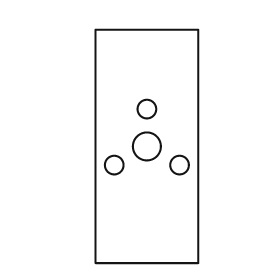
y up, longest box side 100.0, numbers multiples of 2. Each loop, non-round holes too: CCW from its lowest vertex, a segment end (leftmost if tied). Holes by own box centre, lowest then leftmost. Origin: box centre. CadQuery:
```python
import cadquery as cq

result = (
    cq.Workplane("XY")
    .moveTo(-22.0, -50.0)
    .lineTo(22.0, -50.0)
    .lineTo(22.0, 50.0)
    .lineTo(-22.0, 50.0)
    .close()
    .moveTo(-14.0, -8.0)
    .circle(4.0)
    .moveTo(14.0, -8.0)
    .circle(4.0)
    .moveTo(0.0, 0.0)
    .circle(6.0)
    .moveTo(0.0, 16.0)
    .circle(4.0)
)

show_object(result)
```